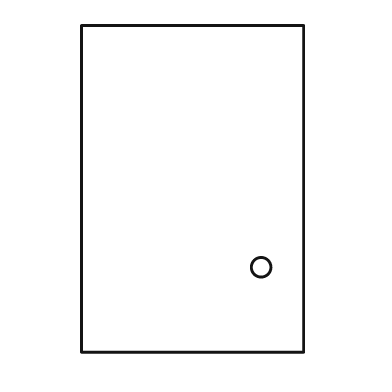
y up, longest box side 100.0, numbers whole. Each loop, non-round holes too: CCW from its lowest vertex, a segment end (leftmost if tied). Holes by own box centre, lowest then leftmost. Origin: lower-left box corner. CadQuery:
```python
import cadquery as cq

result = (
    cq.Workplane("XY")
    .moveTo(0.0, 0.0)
    .lineTo(68.0, 0.0)
    .lineTo(68.0, 100.0)
    .lineTo(0.0, 100.0)
    .close()
    .moveTo(55.0, 26.0)
    .circle(3.0)
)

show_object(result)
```